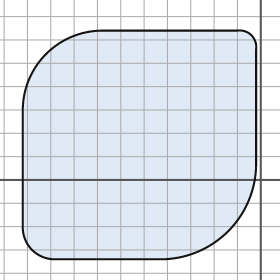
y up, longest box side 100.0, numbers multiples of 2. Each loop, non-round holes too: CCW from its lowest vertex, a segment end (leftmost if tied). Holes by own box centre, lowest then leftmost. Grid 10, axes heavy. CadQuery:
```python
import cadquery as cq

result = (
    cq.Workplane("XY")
    .moveTo(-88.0, -34.0)
    .lineTo(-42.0, -34.0)
    .threePointArc((-14.0, -22.0), (-2.0, 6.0))
    .lineTo(-2.0, 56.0)
    .threePointArc((-4.0, 62.0), (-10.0, 64.0))
    .lineTo(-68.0, 64.0)
    .threePointArc((-92.0, 54.0), (-102.0, 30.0))
    .lineTo(-102.0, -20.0)
    .threePointArc((-98.0, -30.0), (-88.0, -34.0))
    .close()
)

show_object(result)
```